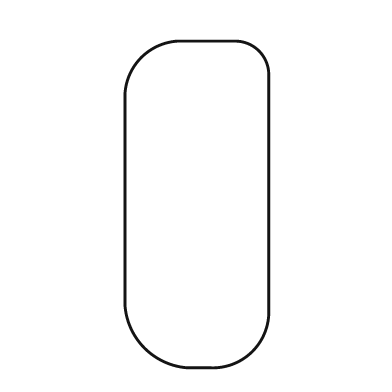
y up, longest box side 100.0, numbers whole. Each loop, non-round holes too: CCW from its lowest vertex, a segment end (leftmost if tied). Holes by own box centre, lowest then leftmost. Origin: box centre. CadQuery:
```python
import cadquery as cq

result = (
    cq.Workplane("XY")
    .moveTo(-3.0, -50.0)
    .lineTo(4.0, -50.0)
    .threePointArc((17.0, -45.0), (22.0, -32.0))
    .lineTo(22.0, 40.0)
    .threePointArc((19.0, 47.0), (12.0, 50.0))
    .lineTo(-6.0, 50.0)
    .threePointArc((-17.0, 45.0), (-22.0, 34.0))
    .lineTo(-22.0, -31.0)
    .threePointArc((-16.0, -44.0), (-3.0, -50.0))
    .close()
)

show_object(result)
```